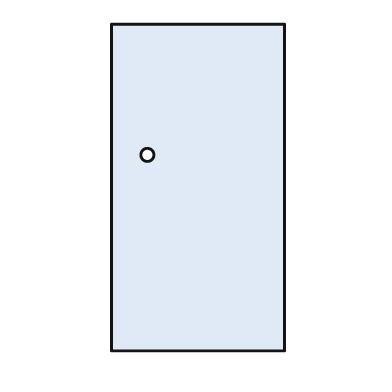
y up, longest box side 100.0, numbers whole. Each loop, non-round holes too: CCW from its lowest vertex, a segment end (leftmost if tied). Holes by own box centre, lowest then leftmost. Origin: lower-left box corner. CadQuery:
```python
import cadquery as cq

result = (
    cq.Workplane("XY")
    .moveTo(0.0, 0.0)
    .lineTo(53.0, 0.0)
    .lineTo(53.0, 100.0)
    .lineTo(0.0, 100.0)
    .close()
    .moveTo(11.0, 60.0)
    .circle(2.0)
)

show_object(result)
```